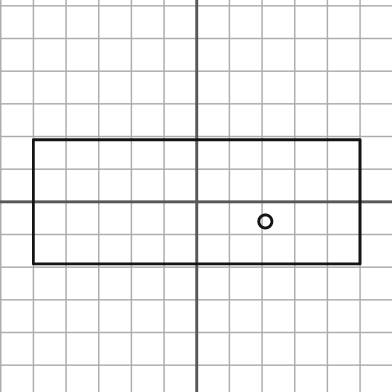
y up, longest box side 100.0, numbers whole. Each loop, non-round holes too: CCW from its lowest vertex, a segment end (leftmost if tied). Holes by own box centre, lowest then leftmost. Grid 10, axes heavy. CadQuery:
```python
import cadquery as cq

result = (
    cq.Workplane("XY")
    .moveTo(-50.0, -19.0)
    .lineTo(50.0, -19.0)
    .lineTo(50.0, 19.0)
    .lineTo(-50.0, 19.0)
    .close()
    .moveTo(21.0, -6.0)
    .circle(2.0)
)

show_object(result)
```